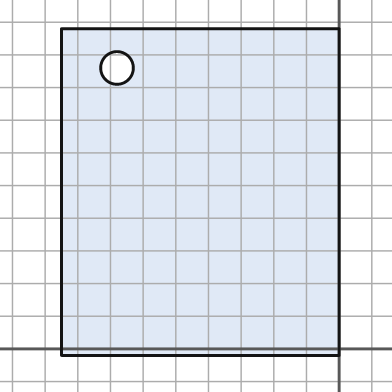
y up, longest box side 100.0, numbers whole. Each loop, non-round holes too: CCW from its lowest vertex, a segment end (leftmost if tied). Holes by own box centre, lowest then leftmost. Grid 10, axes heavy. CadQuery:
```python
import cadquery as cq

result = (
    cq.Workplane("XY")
    .moveTo(-85.0, -2.0)
    .lineTo(0.0, -2.0)
    .lineTo(0.0, 98.0)
    .lineTo(-85.0, 98.0)
    .close()
    .moveTo(-68.0, 86.0)
    .circle(5.0)
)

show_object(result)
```